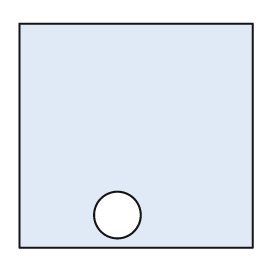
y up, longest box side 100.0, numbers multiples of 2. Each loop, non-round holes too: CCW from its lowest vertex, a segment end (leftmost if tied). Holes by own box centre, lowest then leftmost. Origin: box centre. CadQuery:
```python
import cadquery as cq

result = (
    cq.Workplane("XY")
    .moveTo(-50.0, -48.0)
    .lineTo(50.0, -48.0)
    .lineTo(50.0, 48.0)
    .lineTo(-50.0, 48.0)
    .close()
    .moveTo(-8.0, -34.0)
    .circle(10.0)
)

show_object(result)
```